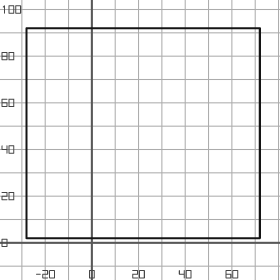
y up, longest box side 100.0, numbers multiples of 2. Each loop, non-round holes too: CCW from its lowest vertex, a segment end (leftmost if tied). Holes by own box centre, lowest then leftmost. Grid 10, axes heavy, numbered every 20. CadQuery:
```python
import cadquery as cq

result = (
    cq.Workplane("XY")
    .moveTo(-28.0, 2.0)
    .lineTo(72.0, 2.0)
    .lineTo(72.0, 92.0)
    .lineTo(-28.0, 92.0)
    .close()
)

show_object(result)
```